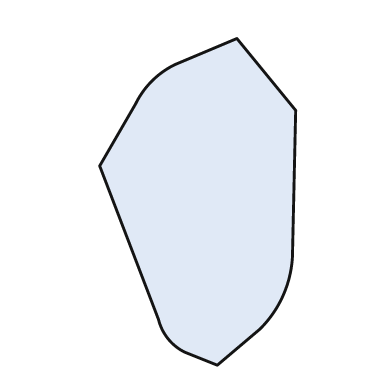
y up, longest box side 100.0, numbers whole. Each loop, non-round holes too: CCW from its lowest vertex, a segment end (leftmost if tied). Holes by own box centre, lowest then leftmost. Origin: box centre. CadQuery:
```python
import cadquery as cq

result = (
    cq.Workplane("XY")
    .moveTo(6.0, -50.0)
    .lineTo(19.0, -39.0)
    .threePointArc((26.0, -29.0), (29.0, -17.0))
    .lineTo(30.0, 28.0)
    .lineTo(12.0, 50.0)
    .lineTo(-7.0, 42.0)
    .threePointArc((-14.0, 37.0), (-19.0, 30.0))
    .lineTo(-30.0, 11.0)
    .lineTo(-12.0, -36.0)
    .threePointArc((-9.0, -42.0), (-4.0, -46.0))
    .close()
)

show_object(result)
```